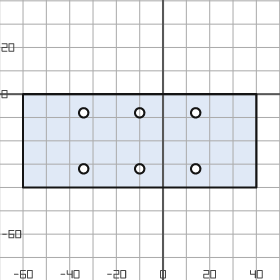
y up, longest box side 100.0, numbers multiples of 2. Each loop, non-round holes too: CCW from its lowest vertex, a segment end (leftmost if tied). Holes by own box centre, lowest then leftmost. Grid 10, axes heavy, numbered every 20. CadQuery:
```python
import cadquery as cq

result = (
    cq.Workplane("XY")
    .moveTo(-60.0, -40.0)
    .lineTo(40.0, -40.0)
    .lineTo(40.0, 0.0)
    .lineTo(-60.0, 0.0)
    .close()
    .moveTo(-34.0, -32.0)
    .circle(2.0)
    .moveTo(-10.0, -32.0)
    .circle(2.0)
    .moveTo(14.0, -32.0)
    .circle(2.0)
    .moveTo(-34.0, -8.0)
    .circle(2.0)
    .moveTo(-10.0, -8.0)
    .circle(2.0)
    .moveTo(14.0, -8.0)
    .circle(2.0)
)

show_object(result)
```